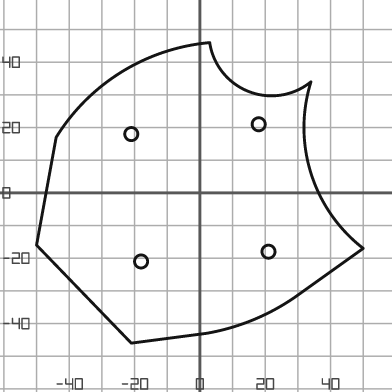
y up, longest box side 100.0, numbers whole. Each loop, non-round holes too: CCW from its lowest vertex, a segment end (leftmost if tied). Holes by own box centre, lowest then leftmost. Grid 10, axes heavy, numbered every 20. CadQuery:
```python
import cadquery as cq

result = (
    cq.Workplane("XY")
    .moveTo(-21.0, -46.0)
    .lineTo(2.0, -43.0)
    .threePointArc((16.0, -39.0), (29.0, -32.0))
    .lineTo(50.0, -17.0)
    .threePointArc((34.0, 6.0), (34.0, 34.0))
    .threePointArc((15.0, 31.0), (3.0, 46.0))
    .threePointArc((-24.0, 37.0), (-44.0, 17.0))
    .lineTo(-50.0, -16.0)
    .close()
    .moveTo(-18.0, -21.0)
    .circle(2.0)
    .moveTo(21.0, -18.0)
    .circle(2.0)
    .moveTo(-21.0, 18.0)
    .circle(2.0)
    .moveTo(18.0, 21.0)
    .circle(2.0)
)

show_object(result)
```